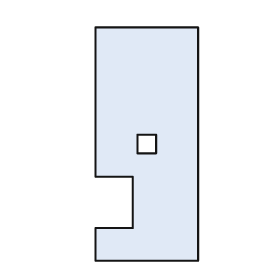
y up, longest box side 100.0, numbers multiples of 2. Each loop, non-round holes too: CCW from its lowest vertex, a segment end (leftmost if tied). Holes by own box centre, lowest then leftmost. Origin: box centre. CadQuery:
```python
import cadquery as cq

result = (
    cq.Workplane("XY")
    .moveTo(-22.0, -50.0)
    .lineTo(22.0, -50.0)
    .lineTo(22.0, 50.0)
    .lineTo(-22.0, 50.0)
    .lineTo(-22.0, -14.0)
    .lineTo(-6.0, -14.0)
    .lineTo(-6.0, -36.0)
    .lineTo(-22.0, -36.0)
    .close()
    .moveTo(-4.0, -4.0)
    .lineTo(4.0, -4.0)
    .lineTo(4.0, 4.0)
    .lineTo(-4.0, 4.0)
    .close()
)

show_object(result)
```